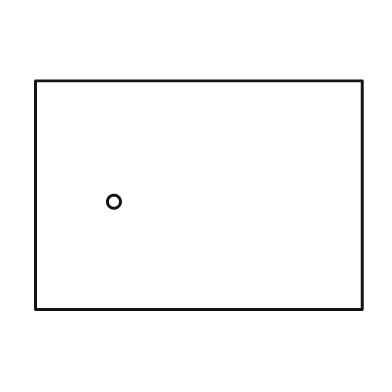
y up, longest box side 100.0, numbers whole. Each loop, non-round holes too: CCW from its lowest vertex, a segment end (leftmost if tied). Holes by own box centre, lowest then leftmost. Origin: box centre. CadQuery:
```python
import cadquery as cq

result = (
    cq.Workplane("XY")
    .moveTo(-50.0, -35.0)
    .lineTo(50.0, -35.0)
    .lineTo(50.0, 35.0)
    .lineTo(-50.0, 35.0)
    .close()
    .moveTo(-26.0, -2.0)
    .circle(2.0)
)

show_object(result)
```